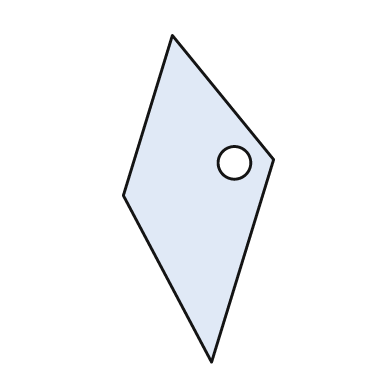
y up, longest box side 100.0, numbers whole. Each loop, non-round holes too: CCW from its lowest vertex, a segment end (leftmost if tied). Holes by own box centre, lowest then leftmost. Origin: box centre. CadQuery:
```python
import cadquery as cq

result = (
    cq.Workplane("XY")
    .moveTo(4.0, -50.0)
    .lineTo(23.0, 12.0)
    .lineTo(-8.0, 50.0)
    .lineTo(-23.0, 1.0)
    .close()
    .moveTo(11.0, 11.0)
    .circle(5.0)
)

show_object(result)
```